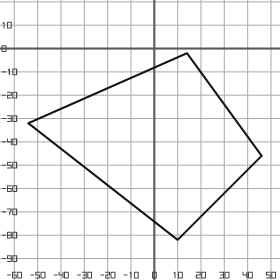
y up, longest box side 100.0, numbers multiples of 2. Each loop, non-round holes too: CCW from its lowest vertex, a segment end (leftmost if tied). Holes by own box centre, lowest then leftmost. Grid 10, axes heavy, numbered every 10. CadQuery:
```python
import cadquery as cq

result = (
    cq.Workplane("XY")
    .moveTo(10.0, -82.0)
    .lineTo(46.0, -46.0)
    .lineTo(14.0, -2.0)
    .lineTo(-54.0, -32.0)
    .close()
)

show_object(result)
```